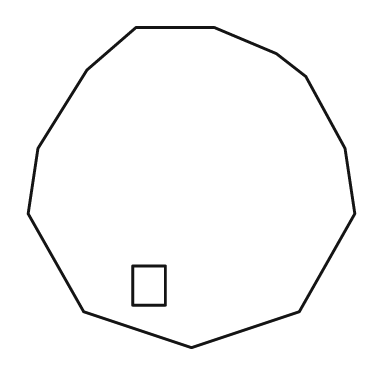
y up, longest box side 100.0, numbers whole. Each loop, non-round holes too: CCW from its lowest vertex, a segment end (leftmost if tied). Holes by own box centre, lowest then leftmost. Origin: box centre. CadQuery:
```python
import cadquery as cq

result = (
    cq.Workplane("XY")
    .moveTo(0.0, -49.0)
    .lineTo(33.0, -38.0)
    .lineTo(50.0, -8.0)
    .lineTo(47.0, 12.0)
    .lineTo(35.0, 34.0)
    .lineTo(26.0, 41.0)
    .lineTo(7.0, 49.0)
    .lineTo(-17.0, 49.0)
    .lineTo(-32.0, 36.0)
    .lineTo(-47.0, 12.0)
    .lineTo(-50.0, -8.0)
    .lineTo(-33.0, -38.0)
    .close()
    .moveTo(-18.0, -36.0)
    .lineTo(-8.0, -36.0)
    .lineTo(-8.0, -24.0)
    .lineTo(-18.0, -24.0)
    .close()
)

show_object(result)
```